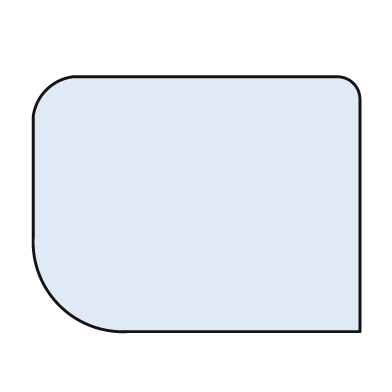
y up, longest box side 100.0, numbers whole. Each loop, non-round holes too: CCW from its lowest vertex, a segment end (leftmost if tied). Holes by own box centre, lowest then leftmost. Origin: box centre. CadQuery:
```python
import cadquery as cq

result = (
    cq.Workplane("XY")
    .moveTo(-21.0, -39.0)
    .lineTo(50.0, -39.0)
    .lineTo(50.0, 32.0)
    .threePointArc((48.0, 37.0), (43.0, 39.0))
    .lineTo(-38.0, 39.0)
    .threePointArc((-46.0, 35.0), (-50.0, 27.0))
    .lineTo(-50.0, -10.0)
    .threePointArc((-42.0, -31.0), (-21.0, -39.0))
    .close()
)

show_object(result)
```